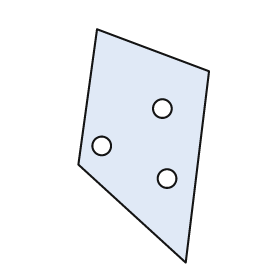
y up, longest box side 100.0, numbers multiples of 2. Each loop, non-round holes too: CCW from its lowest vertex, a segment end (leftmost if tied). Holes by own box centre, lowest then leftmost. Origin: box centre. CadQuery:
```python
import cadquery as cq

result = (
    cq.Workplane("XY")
    .moveTo(18.0, -50.0)
    .lineTo(28.0, 32.0)
    .lineTo(-20.0, 50.0)
    .lineTo(-28.0, -8.0)
    .close()
    .moveTo(10.0, -14.0)
    .circle(4.0)
    .moveTo(-18.0, 0.0)
    .circle(4.0)
    .moveTo(8.0, 16.0)
    .circle(4.0)
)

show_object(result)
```